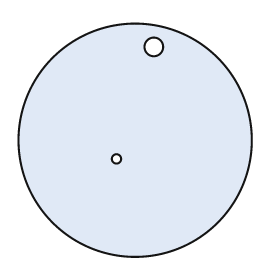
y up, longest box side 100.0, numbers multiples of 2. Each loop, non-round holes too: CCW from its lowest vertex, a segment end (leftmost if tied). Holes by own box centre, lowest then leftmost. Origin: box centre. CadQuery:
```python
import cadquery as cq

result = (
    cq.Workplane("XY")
    .moveTo(0.0, 0.0)
    .circle(50.0)
    .moveTo(-8.0, -8.0)
    .circle(2.0)
    .moveTo(8.0, 40.0)
    .circle(4.0)
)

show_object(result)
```